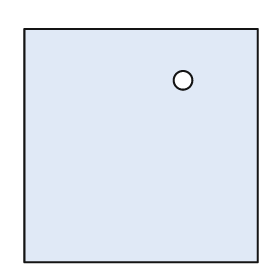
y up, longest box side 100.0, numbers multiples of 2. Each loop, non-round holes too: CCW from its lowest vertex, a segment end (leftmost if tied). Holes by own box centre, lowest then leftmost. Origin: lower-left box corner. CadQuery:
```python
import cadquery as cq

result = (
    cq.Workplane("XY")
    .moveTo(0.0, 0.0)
    .lineTo(100.0, 0.0)
    .lineTo(100.0, 100.0)
    .lineTo(0.0, 100.0)
    .close()
    .moveTo(68.0, 78.0)
    .circle(4.0)
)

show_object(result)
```